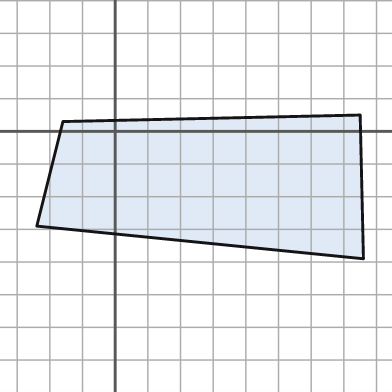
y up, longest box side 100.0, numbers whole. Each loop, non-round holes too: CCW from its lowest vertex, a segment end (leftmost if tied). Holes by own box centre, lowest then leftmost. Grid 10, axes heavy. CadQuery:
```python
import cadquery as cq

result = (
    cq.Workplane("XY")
    .moveTo(76.0, -39.0)
    .lineTo(75.0, 5.0)
    .lineTo(-16.0, 3.0)
    .lineTo(-24.0, -29.0)
    .close()
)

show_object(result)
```